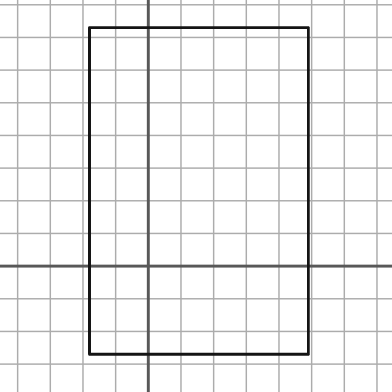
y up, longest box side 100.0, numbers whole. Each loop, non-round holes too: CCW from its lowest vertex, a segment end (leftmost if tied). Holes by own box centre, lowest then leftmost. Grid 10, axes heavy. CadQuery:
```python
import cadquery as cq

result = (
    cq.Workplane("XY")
    .moveTo(-18.0, -27.0)
    .lineTo(49.0, -27.0)
    .lineTo(49.0, 73.0)
    .lineTo(-18.0, 73.0)
    .close()
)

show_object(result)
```